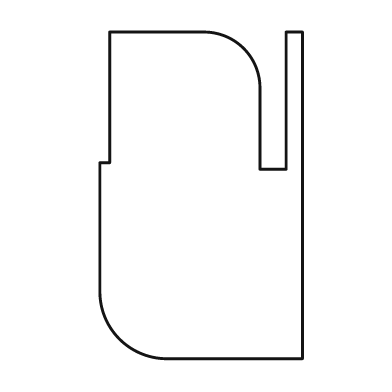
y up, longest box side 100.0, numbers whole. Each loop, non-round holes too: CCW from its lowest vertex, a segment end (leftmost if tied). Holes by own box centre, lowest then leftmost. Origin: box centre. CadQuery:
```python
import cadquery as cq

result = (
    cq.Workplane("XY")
    .moveTo(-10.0, -50.0)
    .lineTo(31.0, -50.0)
    .lineTo(31.0, 50.0)
    .lineTo(26.0, 50.0)
    .lineTo(26.0, 8.0)
    .lineTo(18.0, 8.0)
    .lineTo(18.0, 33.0)
    .threePointArc((13.0, 45.0), (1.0, 50.0))
    .lineTo(-28.0, 50.0)
    .lineTo(-28.0, 10.0)
    .lineTo(-31.0, 10.0)
    .lineTo(-31.0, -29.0)
    .threePointArc((-25.0, -44.0), (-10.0, -50.0))
    .close()
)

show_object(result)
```